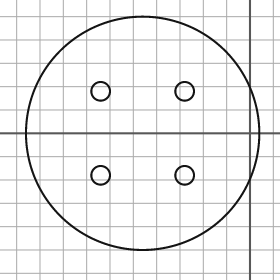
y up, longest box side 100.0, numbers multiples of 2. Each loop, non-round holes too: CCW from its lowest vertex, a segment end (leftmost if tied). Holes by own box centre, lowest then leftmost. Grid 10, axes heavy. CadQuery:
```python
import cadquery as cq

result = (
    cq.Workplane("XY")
    .moveTo(-46.0, 0.0)
    .circle(50.0)
    .moveTo(-64.0, -18.0)
    .circle(4.0)
    .moveTo(-28.0, -18.0)
    .circle(4.0)
    .moveTo(-64.0, 18.0)
    .circle(4.0)
    .moveTo(-28.0, 18.0)
    .circle(4.0)
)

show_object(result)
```